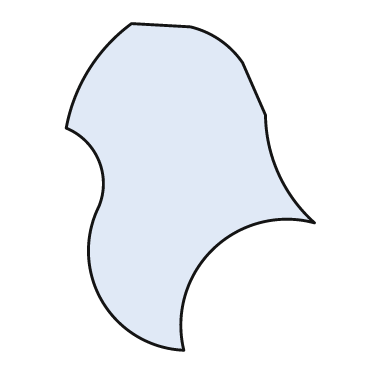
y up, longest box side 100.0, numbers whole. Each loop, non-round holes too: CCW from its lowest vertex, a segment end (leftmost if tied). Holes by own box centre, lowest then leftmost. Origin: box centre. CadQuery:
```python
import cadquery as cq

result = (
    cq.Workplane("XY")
    .moveTo(-2.0, -50.0)
    .threePointArc((7.0, -19.0), (38.0, -11.0))
    .threePointArc((27.0, 4.0), (23.0, 22.0))
    .lineTo(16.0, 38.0)
    .threePointArc((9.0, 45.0), (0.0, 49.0))
    .lineTo(-18.0, 50.0)
    .threePointArc((-31.0, 36.0), (-38.0, 18.0))
    .threePointArc((-28.0, 8.0), (-28.0, -6.0))
    .threePointArc((-27.0, -35.0), (-2.0, -50.0))
    .close()
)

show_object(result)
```